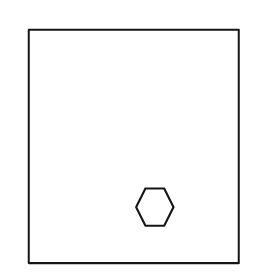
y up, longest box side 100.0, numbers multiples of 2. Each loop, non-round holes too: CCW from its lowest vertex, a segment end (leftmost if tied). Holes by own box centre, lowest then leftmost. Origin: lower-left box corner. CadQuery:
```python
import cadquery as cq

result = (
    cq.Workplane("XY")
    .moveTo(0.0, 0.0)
    .lineTo(90.0, 0.0)
    .lineTo(90.0, 100.0)
    .lineTo(0.0, 100.0)
    .close()
    .moveTo(50.0, 16.0)
    .lineTo(58.0, 16.0)
    .lineTo(62.0, 24.0)
    .lineTo(58.0, 32.0)
    .lineTo(50.0, 32.0)
    .lineTo(46.0, 24.0)
    .close()
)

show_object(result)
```